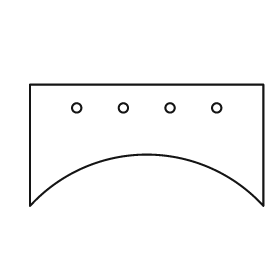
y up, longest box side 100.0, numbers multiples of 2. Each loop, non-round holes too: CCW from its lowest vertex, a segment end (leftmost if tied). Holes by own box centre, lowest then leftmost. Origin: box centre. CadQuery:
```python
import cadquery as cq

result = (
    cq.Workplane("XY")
    .moveTo(-50.0, -26.0)
    .threePointArc((0.0, -4.0), (50.0, -26.0))
    .lineTo(50.0, 26.0)
    .lineTo(-50.0, 26.0)
    .close()
    .moveTo(-30.0, 16.0)
    .circle(2.0)
    .moveTo(-10.0, 16.0)
    .circle(2.0)
    .moveTo(10.0, 16.0)
    .circle(2.0)
    .moveTo(30.0, 16.0)
    .circle(2.0)
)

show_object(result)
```